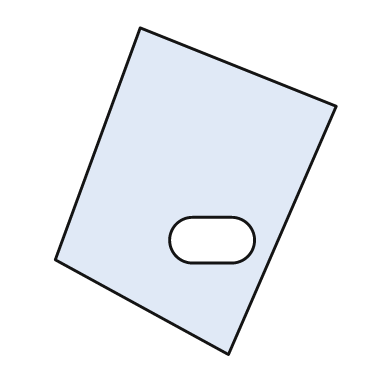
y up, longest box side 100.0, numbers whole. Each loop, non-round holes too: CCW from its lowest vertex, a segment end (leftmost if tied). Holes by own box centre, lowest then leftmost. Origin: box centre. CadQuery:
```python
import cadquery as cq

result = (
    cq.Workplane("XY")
    .moveTo(10.0, -50.0)
    .lineTo(43.0, 26.0)
    .lineTo(-17.0, 50.0)
    .lineTo(-43.0, -21.0)
    .close()
    .moveTo(-1.0, -22.0)
    .lineTo(11.0, -22.0)
    .threePointArc((18.0, -15.0), (11.0, -8.0))
    .lineTo(-1.0, -8.0)
    .threePointArc((-8.0, -15.0), (-1.0, -22.0))
    .close()
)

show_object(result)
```